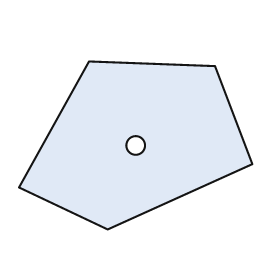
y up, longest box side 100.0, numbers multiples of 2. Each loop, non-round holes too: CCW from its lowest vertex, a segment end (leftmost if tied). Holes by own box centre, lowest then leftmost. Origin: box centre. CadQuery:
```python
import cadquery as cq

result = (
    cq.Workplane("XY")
    .moveTo(-12.0, -36.0)
    .lineTo(50.0, -8.0)
    .lineTo(34.0, 34.0)
    .lineTo(-20.0, 36.0)
    .lineTo(-50.0, -18.0)
    .close()
    .moveTo(0.0, 0.0)
    .circle(4.0)
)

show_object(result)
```